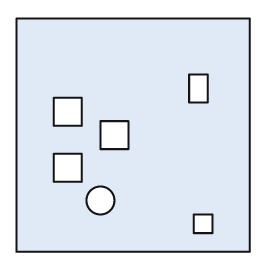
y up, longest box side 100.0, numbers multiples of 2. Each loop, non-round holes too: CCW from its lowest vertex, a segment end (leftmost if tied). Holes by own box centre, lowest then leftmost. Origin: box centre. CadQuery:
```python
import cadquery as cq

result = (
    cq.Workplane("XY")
    .moveTo(-50.0, -50.0)
    .lineTo(50.0, -50.0)
    .lineTo(50.0, 50.0)
    .lineTo(-50.0, 50.0)
    .close()
    .moveTo(26.0, -42.0)
    .lineTo(34.0, -42.0)
    .lineTo(34.0, -34.0)
    .lineTo(26.0, -34.0)
    .close()
    .moveTo(-14.0, -28.0)
    .circle(6.0)
    .moveTo(-34.0, -20.0)
    .lineTo(-22.0, -20.0)
    .lineTo(-22.0, -8.0)
    .lineTo(-34.0, -8.0)
    .close()
    .moveTo(-14.0, -6.0)
    .lineTo(-2.0, -6.0)
    .lineTo(-2.0, 6.0)
    .lineTo(-14.0, 6.0)
    .close()
    .moveTo(-34.0, 4.0)
    .lineTo(-22.0, 4.0)
    .lineTo(-22.0, 16.0)
    .lineTo(-34.0, 16.0)
    .close()
    .moveTo(24.0, 14.0)
    .lineTo(32.0, 14.0)
    .lineTo(32.0, 26.0)
    .lineTo(24.0, 26.0)
    .close()
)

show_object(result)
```